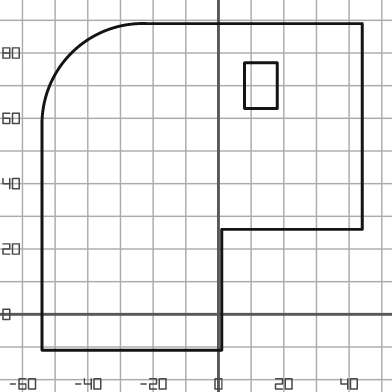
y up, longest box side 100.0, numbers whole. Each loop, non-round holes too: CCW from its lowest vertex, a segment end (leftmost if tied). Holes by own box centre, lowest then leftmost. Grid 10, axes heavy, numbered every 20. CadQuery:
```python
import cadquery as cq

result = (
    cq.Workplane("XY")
    .moveTo(-54.0, -11.0)
    .lineTo(1.0, -11.0)
    .lineTo(1.0, 26.0)
    .lineTo(44.0, 26.0)
    .lineTo(44.0, 89.0)
    .lineTo(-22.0, 89.0)
    .threePointArc((-45.0, 80.0), (-54.0, 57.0))
    .close()
    .moveTo(8.0, 63.0)
    .lineTo(18.0, 63.0)
    .lineTo(18.0, 77.0)
    .lineTo(8.0, 77.0)
    .close()
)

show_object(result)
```